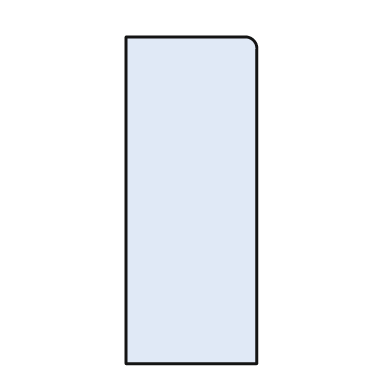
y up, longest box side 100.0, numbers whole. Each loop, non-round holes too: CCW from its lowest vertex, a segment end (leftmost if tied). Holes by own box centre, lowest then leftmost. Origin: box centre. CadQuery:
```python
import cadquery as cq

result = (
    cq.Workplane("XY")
    .moveTo(-20.0, -50.0)
    .lineTo(20.0, -50.0)
    .lineTo(20.0, 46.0)
    .threePointArc((19.0, 49.0), (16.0, 50.0))
    .lineTo(-20.0, 50.0)
    .close()
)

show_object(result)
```